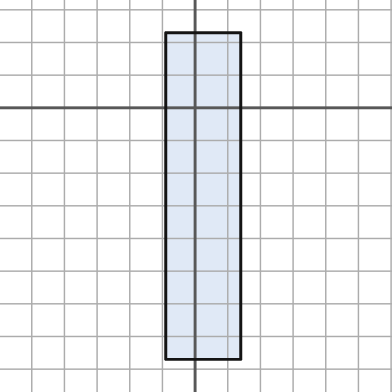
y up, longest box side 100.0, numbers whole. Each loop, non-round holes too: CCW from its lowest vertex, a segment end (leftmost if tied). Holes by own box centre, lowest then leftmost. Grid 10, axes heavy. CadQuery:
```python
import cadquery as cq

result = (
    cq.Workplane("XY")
    .moveTo(-9.0, -77.0)
    .lineTo(14.0, -77.0)
    .lineTo(14.0, 23.0)
    .lineTo(-9.0, 23.0)
    .close()
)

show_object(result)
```